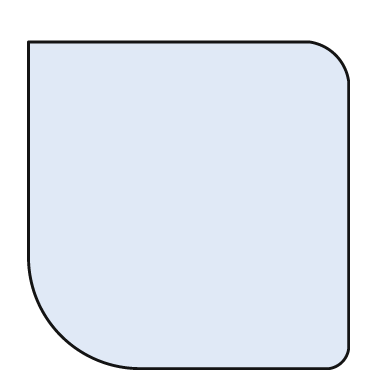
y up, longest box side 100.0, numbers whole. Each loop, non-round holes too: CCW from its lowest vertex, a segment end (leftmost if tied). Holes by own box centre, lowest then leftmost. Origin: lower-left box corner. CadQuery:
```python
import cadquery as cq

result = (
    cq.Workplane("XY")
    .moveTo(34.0, 0.0)
    .lineTo(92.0, 0.0)
    .threePointArc((96.0, 2.0), (98.0, 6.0))
    .lineTo(98.0, 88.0)
    .threePointArc((94.0, 96.0), (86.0, 100.0))
    .lineTo(0.0, 100.0)
    .lineTo(0.0, 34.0)
    .threePointArc((10.0, 10.0), (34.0, 0.0))
    .close()
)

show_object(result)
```